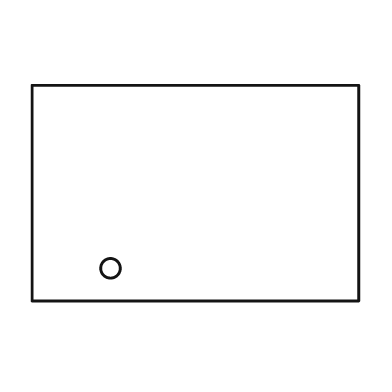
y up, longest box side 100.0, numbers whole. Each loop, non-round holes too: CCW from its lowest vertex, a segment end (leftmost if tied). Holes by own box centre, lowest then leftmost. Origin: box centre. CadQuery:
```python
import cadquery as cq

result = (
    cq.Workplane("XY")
    .moveTo(-50.0, -33.0)
    .lineTo(50.0, -33.0)
    .lineTo(50.0, 33.0)
    .lineTo(-50.0, 33.0)
    .close()
    .moveTo(-26.0, -23.0)
    .circle(3.0)
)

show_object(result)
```